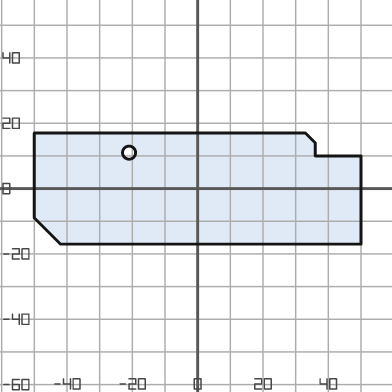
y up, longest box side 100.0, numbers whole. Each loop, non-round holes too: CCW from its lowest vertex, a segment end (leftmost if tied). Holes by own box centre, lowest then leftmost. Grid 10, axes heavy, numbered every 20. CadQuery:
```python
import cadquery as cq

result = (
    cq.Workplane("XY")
    .moveTo(-42.0, -17.0)
    .lineTo(50.0, -17.0)
    .lineTo(50.0, 10.0)
    .lineTo(36.0, 10.0)
    .lineTo(36.0, 14.0)
    .lineTo(33.0, 17.0)
    .lineTo(-50.0, 17.0)
    .lineTo(-50.0, -9.0)
    .close()
    .moveTo(-21.0, 11.0)
    .circle(2.0)
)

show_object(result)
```